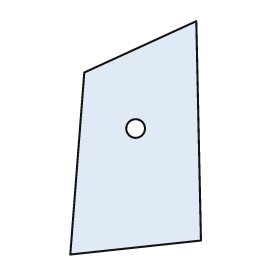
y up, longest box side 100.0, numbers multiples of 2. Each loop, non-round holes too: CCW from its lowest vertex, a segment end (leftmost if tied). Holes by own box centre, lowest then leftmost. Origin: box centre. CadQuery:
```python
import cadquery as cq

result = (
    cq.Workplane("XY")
    .moveTo(-28.0, -50.0)
    .lineTo(28.0, -44.0)
    .lineTo(26.0, 50.0)
    .lineTo(-22.0, 28.0)
    .close()
    .moveTo(0.0, 4.0)
    .circle(4.0)
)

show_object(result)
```